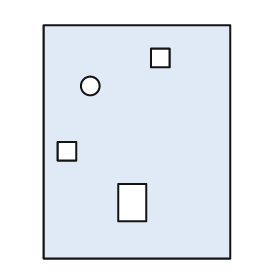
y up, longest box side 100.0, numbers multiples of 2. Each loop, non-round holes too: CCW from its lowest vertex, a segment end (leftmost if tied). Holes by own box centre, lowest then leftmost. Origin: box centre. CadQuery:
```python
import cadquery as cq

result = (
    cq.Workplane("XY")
    .moveTo(-40.0, -50.0)
    .lineTo(40.0, -50.0)
    .lineTo(40.0, 50.0)
    .lineTo(-40.0, 50.0)
    .close()
    .moveTo(-8.0, -34.0)
    .lineTo(4.0, -34.0)
    .lineTo(4.0, -18.0)
    .lineTo(-8.0, -18.0)
    .close()
    .moveTo(-34.0, -8.0)
    .lineTo(-26.0, -8.0)
    .lineTo(-26.0, 0.0)
    .lineTo(-34.0, 0.0)
    .close()
    .moveTo(-20.0, 24.0)
    .circle(4.0)
    .moveTo(6.0, 32.0)
    .lineTo(14.0, 32.0)
    .lineTo(14.0, 40.0)
    .lineTo(6.0, 40.0)
    .close()
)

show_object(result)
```